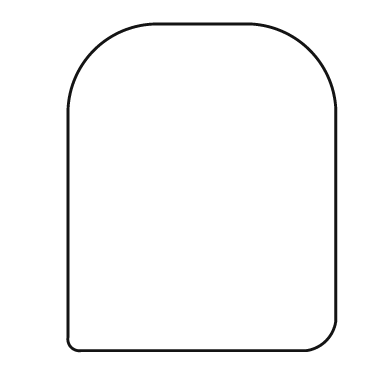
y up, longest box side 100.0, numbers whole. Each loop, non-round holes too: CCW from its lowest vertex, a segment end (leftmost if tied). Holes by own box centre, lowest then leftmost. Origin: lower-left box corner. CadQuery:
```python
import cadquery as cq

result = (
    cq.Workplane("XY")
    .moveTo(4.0, 0.0)
    .lineTo(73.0, 0.0)
    .threePointArc((79.0, 3.0), (82.0, 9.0))
    .lineTo(82.0, 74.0)
    .threePointArc((74.0, 92.0), (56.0, 100.0))
    .lineTo(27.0, 100.0)
    .threePointArc((8.0, 92.0), (0.0, 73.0))
    .lineTo(0.0, 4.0)
    .threePointArc((1.0, 1.0), (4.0, 0.0))
    .close()
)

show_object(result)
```